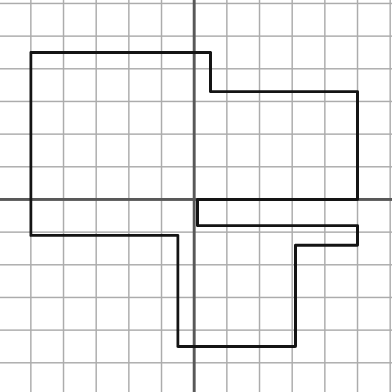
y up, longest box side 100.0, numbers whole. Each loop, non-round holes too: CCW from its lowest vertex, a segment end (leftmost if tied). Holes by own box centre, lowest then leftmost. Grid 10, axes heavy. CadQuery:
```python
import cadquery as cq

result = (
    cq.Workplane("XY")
    .moveTo(-5.0, -45.0)
    .lineTo(31.0, -45.0)
    .lineTo(31.0, -14.0)
    .lineTo(50.0, -14.0)
    .lineTo(50.0, -8.0)
    .lineTo(1.0, -8.0)
    .lineTo(1.0, 0.0)
    .lineTo(50.0, 0.0)
    .lineTo(50.0, 33.0)
    .lineTo(5.0, 33.0)
    .lineTo(5.0, 45.0)
    .lineTo(-50.0, 45.0)
    .lineTo(-50.0, -11.0)
    .lineTo(-5.0, -11.0)
    .close()
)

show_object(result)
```